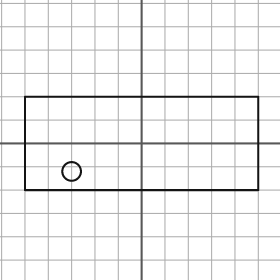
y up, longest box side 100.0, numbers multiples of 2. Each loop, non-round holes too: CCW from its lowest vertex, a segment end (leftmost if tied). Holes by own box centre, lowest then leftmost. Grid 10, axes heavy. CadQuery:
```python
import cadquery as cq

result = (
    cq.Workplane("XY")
    .moveTo(-50.0, -20.0)
    .lineTo(50.0, -20.0)
    .lineTo(50.0, 20.0)
    .lineTo(-50.0, 20.0)
    .close()
    .moveTo(-30.0, -12.0)
    .circle(4.0)
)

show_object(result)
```